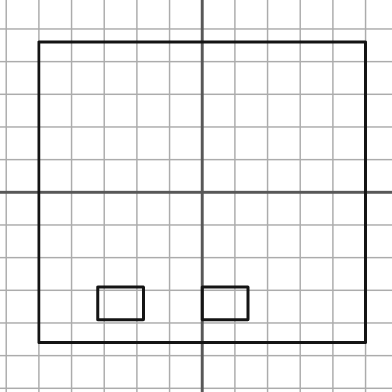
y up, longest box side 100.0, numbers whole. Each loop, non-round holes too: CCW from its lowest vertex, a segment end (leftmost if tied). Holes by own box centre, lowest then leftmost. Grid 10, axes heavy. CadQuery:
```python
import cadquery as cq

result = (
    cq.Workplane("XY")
    .moveTo(-50.0, -46.0)
    .lineTo(50.0, -46.0)
    .lineTo(50.0, 46.0)
    .lineTo(-50.0, 46.0)
    .close()
    .moveTo(-32.0, -39.0)
    .lineTo(-18.0, -39.0)
    .lineTo(-18.0, -29.0)
    .lineTo(-32.0, -29.0)
    .close()
    .moveTo(0.0, -39.0)
    .lineTo(14.0, -39.0)
    .lineTo(14.0, -29.0)
    .lineTo(0.0, -29.0)
    .close()
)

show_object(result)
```